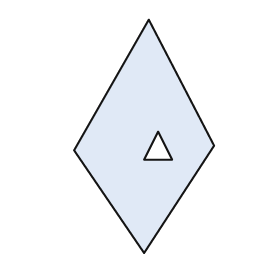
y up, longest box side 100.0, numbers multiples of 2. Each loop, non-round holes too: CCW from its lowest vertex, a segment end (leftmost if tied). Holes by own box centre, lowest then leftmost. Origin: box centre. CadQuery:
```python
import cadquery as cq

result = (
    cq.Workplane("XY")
    .moveTo(0.0, -50.0)
    .lineTo(30.0, -4.0)
    .lineTo(2.0, 50.0)
    .lineTo(-30.0, -6.0)
    .close()
    .moveTo(0.0, -10.0)
    .lineTo(12.0, -10.0)
    .lineTo(6.0, 2.0)
    .close()
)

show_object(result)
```